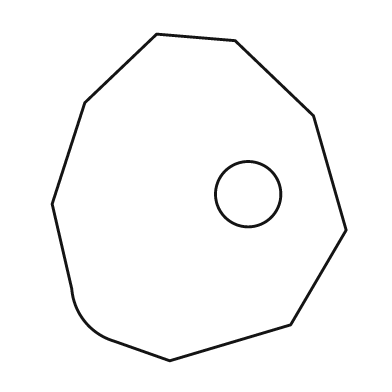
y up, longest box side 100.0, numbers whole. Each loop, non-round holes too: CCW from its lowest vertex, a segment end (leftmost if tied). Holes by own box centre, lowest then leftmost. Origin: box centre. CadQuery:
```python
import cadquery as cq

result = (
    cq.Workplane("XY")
    .moveTo(-9.0, -50.0)
    .lineTo(28.0, -39.0)
    .lineTo(45.0, -10.0)
    .lineTo(35.0, 25.0)
    .lineTo(11.0, 48.0)
    .lineTo(-13.0, 50.0)
    .lineTo(-35.0, 29.0)
    .lineTo(-45.0, -2.0)
    .lineTo(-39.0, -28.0)
    .threePointArc((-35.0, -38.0), (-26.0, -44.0))
    .close()
    .moveTo(15.0, 1.0)
    .circle(10.0)
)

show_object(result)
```